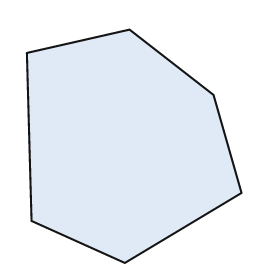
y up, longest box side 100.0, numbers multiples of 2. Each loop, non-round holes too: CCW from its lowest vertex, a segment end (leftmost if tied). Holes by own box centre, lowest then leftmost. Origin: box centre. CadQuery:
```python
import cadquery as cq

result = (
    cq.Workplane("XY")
    .moveTo(-4.0, -50.0)
    .lineTo(46.0, -20.0)
    .lineTo(34.0, 22.0)
    .lineTo(-2.0, 50.0)
    .lineTo(-46.0, 40.0)
    .lineTo(-44.0, -32.0)
    .close()
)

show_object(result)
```